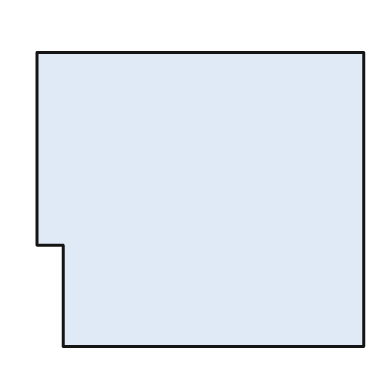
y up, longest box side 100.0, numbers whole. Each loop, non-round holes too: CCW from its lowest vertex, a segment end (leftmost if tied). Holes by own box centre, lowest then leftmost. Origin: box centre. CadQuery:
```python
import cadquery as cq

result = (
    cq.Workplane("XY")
    .moveTo(-42.0, -45.0)
    .lineTo(50.0, -45.0)
    .lineTo(50.0, 45.0)
    .lineTo(-50.0, 45.0)
    .lineTo(-50.0, -14.0)
    .lineTo(-42.0, -14.0)
    .close()
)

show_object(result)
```